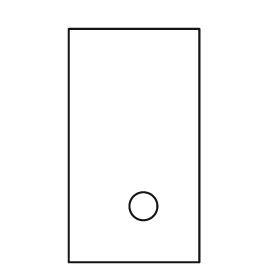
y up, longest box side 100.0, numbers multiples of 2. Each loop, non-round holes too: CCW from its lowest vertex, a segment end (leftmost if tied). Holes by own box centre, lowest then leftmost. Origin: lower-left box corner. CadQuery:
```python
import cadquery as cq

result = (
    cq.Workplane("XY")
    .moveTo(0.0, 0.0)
    .lineTo(56.0, 0.0)
    .lineTo(56.0, 100.0)
    .lineTo(0.0, 100.0)
    .close()
    .moveTo(32.0, 24.0)
    .circle(6.0)
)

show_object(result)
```